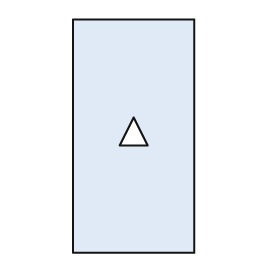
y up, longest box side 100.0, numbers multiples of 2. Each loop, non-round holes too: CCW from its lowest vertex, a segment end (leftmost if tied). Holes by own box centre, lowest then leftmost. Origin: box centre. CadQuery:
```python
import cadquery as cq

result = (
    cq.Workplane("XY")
    .moveTo(-26.0, -50.0)
    .lineTo(26.0, -50.0)
    .lineTo(26.0, 50.0)
    .lineTo(-26.0, 50.0)
    .close()
    .moveTo(-6.0, -4.0)
    .lineTo(6.0, -4.0)
    .lineTo(0.0, 8.0)
    .close()
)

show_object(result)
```